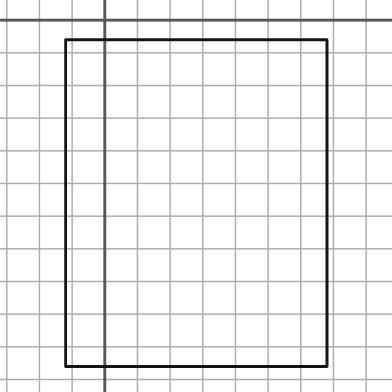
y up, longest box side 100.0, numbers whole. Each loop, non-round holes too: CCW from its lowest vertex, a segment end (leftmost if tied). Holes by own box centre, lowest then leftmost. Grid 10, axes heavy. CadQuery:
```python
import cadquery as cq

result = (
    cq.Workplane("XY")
    .moveTo(-12.0, -106.0)
    .lineTo(68.0, -106.0)
    .lineTo(68.0, -6.0)
    .lineTo(-12.0, -6.0)
    .close()
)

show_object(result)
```